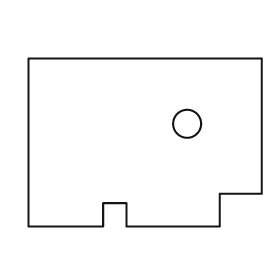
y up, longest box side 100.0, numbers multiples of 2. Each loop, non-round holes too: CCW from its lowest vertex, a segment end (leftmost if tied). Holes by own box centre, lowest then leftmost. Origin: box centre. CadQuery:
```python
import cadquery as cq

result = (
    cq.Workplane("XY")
    .moveTo(-50.0, -36.0)
    .lineTo(-18.0, -36.0)
    .lineTo(-18.0, -26.0)
    .lineTo(-8.0, -26.0)
    .lineTo(-8.0, -36.0)
    .lineTo(32.0, -36.0)
    .lineTo(32.0, -22.0)
    .lineTo(50.0, -22.0)
    .lineTo(50.0, 36.0)
    .lineTo(-50.0, 36.0)
    .close()
    .moveTo(18.0, 8.0)
    .circle(6.0)
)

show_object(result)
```